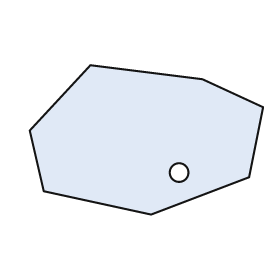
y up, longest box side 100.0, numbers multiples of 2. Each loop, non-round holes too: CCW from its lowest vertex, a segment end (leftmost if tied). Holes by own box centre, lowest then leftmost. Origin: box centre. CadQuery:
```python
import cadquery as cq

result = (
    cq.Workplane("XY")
    .moveTo(2.0, -32.0)
    .lineTo(44.0, -16.0)
    .lineTo(50.0, 14.0)
    .lineTo(24.0, 26.0)
    .lineTo(-24.0, 32.0)
    .lineTo(-50.0, 4.0)
    .lineTo(-44.0, -22.0)
    .close()
    .moveTo(14.0, -14.0)
    .circle(4.0)
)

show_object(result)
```